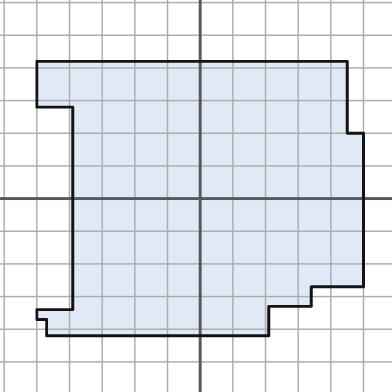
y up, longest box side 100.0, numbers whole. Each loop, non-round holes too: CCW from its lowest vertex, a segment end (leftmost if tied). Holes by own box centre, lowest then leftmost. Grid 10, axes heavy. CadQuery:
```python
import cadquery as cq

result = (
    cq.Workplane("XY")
    .moveTo(-47.0, -42.0)
    .lineTo(21.0, -42.0)
    .lineTo(21.0, -33.0)
    .lineTo(34.0, -33.0)
    .lineTo(34.0, -27.0)
    .lineTo(50.0, -27.0)
    .lineTo(50.0, 20.0)
    .lineTo(45.0, 20.0)
    .lineTo(45.0, 42.0)
    .lineTo(-50.0, 42.0)
    .lineTo(-50.0, 28.0)
    .lineTo(-39.0, 28.0)
    .lineTo(-39.0, -34.0)
    .lineTo(-50.0, -34.0)
    .lineTo(-50.0, -37.0)
    .lineTo(-47.0, -37.0)
    .close()
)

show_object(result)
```